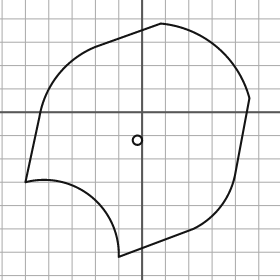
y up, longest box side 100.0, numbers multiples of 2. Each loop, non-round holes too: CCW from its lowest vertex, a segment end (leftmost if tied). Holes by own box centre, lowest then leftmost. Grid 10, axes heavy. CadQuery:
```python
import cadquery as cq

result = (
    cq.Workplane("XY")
    .moveTo(-10.0, -62.0)
    .lineTo(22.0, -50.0)
    .threePointArc((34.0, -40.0), (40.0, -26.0))
    .lineTo(46.0, 6.0)
    .threePointArc((32.0, 28.0), (8.0, 38.0))
    .lineTo(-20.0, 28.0)
    .threePointArc((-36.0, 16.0), (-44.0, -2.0))
    .lineTo(-50.0, -30.0)
    .threePointArc((-22.0, -36.0), (-10.0, -62.0))
    .close()
    .moveTo(-2.0, -12.0)
    .circle(2.0)
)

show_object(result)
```